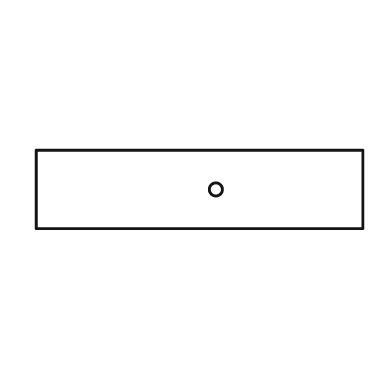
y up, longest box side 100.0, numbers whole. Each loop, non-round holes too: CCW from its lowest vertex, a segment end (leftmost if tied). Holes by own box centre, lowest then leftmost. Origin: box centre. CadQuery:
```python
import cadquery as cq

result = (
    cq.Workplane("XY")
    .moveTo(-50.0, -12.0)
    .lineTo(50.0, -12.0)
    .lineTo(50.0, 12.0)
    .lineTo(-50.0, 12.0)
    .close()
    .moveTo(5.0, 0.0)
    .circle(2.0)
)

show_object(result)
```